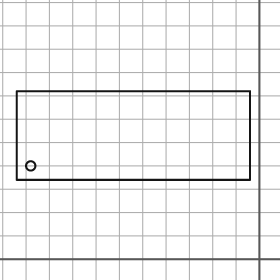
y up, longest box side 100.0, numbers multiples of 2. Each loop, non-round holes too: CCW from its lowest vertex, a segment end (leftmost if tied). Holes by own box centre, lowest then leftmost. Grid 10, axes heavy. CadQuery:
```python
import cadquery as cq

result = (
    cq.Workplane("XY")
    .moveTo(-104.0, 34.0)
    .lineTo(-4.0, 34.0)
    .lineTo(-4.0, 72.0)
    .lineTo(-104.0, 72.0)
    .close()
    .moveTo(-98.0, 40.0)
    .circle(2.0)
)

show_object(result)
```